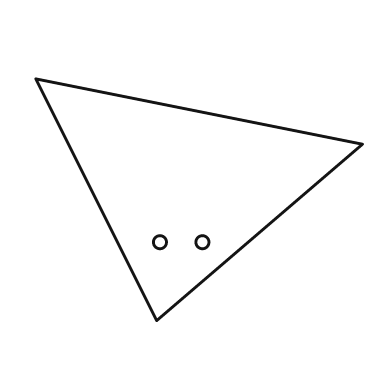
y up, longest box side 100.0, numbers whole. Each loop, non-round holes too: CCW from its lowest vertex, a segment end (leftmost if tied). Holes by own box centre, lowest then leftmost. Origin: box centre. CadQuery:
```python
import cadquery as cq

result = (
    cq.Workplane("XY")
    .moveTo(-13.0, -37.0)
    .lineTo(50.0, 17.0)
    .lineTo(-50.0, 37.0)
    .close()
    .moveTo(-12.0, -13.0)
    .circle(2.0)
    .moveTo(1.0, -13.0)
    .circle(2.0)
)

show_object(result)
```